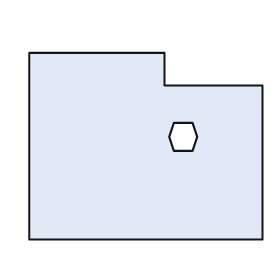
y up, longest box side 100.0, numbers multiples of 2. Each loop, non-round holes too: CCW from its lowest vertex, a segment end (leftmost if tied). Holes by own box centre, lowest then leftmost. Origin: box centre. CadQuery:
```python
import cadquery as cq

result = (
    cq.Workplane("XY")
    .moveTo(-50.0, -40.0)
    .lineTo(50.0, -40.0)
    .lineTo(50.0, 26.0)
    .lineTo(8.0, 26.0)
    .lineTo(8.0, 40.0)
    .lineTo(-50.0, 40.0)
    .close()
    .moveTo(12.0, -2.0)
    .lineTo(20.0, -2.0)
    .lineTo(22.0, 4.0)
    .lineTo(20.0, 10.0)
    .lineTo(12.0, 10.0)
    .lineTo(10.0, 4.0)
    .close()
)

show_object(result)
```